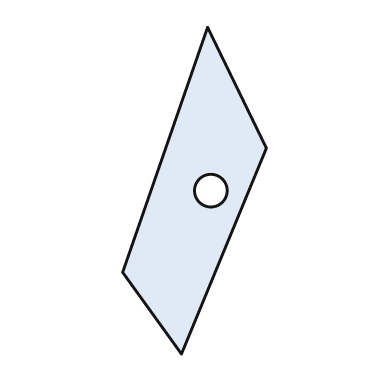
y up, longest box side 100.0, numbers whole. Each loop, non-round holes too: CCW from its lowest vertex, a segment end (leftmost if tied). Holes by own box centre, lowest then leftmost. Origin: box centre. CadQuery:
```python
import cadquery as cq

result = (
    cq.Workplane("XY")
    .moveTo(-4.0, -50.0)
    .lineTo(22.0, 13.0)
    .lineTo(4.0, 50.0)
    .lineTo(-22.0, -25.0)
    .close()
    .moveTo(5.0, 0.0)
    .circle(5.0)
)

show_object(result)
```